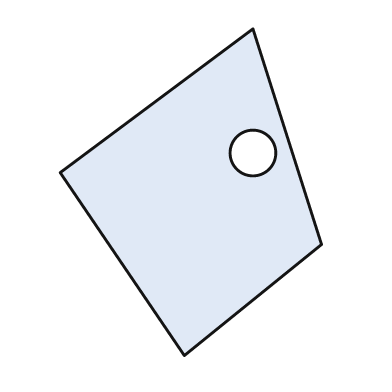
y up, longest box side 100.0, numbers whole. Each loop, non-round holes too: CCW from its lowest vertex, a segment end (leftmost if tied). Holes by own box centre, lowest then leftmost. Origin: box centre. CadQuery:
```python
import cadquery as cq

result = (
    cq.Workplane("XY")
    .moveTo(-2.0, -50.0)
    .lineTo(40.0, -16.0)
    .lineTo(19.0, 50.0)
    .lineTo(-40.0, 6.0)
    .close()
    .moveTo(19.0, 12.0)
    .circle(7.0)
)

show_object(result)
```